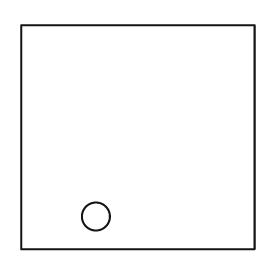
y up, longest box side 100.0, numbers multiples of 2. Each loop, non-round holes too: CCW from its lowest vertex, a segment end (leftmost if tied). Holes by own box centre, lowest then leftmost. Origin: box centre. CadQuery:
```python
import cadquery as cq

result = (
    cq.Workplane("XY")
    .moveTo(-50.0, -48.0)
    .lineTo(50.0, -48.0)
    .lineTo(50.0, 48.0)
    .lineTo(-50.0, 48.0)
    .close()
    .moveTo(-18.0, -34.0)
    .circle(6.0)
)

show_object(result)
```